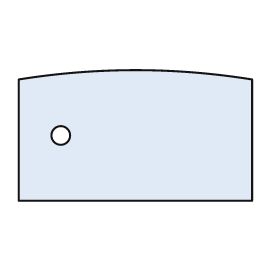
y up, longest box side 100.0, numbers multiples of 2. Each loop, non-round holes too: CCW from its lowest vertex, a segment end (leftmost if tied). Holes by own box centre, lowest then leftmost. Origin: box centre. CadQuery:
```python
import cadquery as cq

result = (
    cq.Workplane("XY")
    .moveTo(-50.0, -28.0)
    .lineTo(50.0, -28.0)
    .lineTo(50.0, 24.0)
    .threePointArc((0.0, 28.0), (-50.0, 24.0))
    .close()
    .moveTo(-32.0, 0.0)
    .circle(4.0)
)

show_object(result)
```